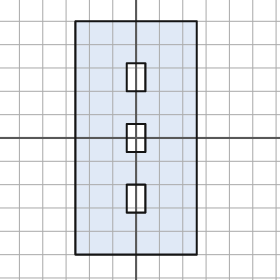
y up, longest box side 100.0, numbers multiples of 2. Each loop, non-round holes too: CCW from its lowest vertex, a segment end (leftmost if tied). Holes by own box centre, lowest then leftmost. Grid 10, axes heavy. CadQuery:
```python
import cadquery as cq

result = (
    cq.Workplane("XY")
    .moveTo(-26.0, -50.0)
    .lineTo(26.0, -50.0)
    .lineTo(26.0, 50.0)
    .lineTo(-26.0, 50.0)
    .close()
    .moveTo(-4.0, -32.0)
    .lineTo(4.0, -32.0)
    .lineTo(4.0, -20.0)
    .lineTo(-4.0, -20.0)
    .close()
    .moveTo(-4.0, -6.0)
    .lineTo(4.0, -6.0)
    .lineTo(4.0, 6.0)
    .lineTo(-4.0, 6.0)
    .close()
    .moveTo(-4.0, 20.0)
    .lineTo(4.0, 20.0)
    .lineTo(4.0, 32.0)
    .lineTo(-4.0, 32.0)
    .close()
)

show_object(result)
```